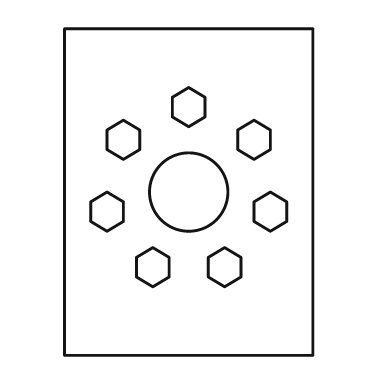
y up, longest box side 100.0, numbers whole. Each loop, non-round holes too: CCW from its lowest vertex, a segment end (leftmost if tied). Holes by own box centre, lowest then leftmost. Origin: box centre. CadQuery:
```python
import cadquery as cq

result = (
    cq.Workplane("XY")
    .moveTo(-38.0, -50.0)
    .lineTo(38.0, -50.0)
    .lineTo(38.0, 50.0)
    .lineTo(-38.0, 50.0)
    .close()
    .moveTo(-11.0, -29.0)
    .lineTo(-6.0, -26.0)
    .lineTo(-6.0, -20.0)
    .lineTo(-11.0, -17.0)
    .lineTo(-16.0, -20.0)
    .lineTo(-16.0, -26.0)
    .close()
    .moveTo(11.0, -29.0)
    .lineTo(16.0, -26.0)
    .lineTo(16.0, -20.0)
    .lineTo(11.0, -17.0)
    .lineTo(6.0, -20.0)
    .lineTo(6.0, -26.0)
    .close()
    .moveTo(-25.0, -12.0)
    .lineTo(-20.0, -9.0)
    .lineTo(-20.0, -3.0)
    .lineTo(-25.0, 0.0)
    .lineTo(-30.0, -3.0)
    .lineTo(-30.0, -9.0)
    .close()
    .moveTo(25.0, -12.0)
    .lineTo(30.0, -9.0)
    .lineTo(30.0, -3.0)
    .lineTo(25.0, 0.0)
    .lineTo(20.0, -3.0)
    .lineTo(20.0, -9.0)
    .close()
    .moveTo(0.0, 0.0)
    .circle(12.0)
    .moveTo(-20.0, 10.0)
    .lineTo(-15.0, 13.0)
    .lineTo(-15.0, 19.0)
    .lineTo(-20.0, 22.0)
    .lineTo(-25.0, 19.0)
    .lineTo(-25.0, 13.0)
    .close()
    .moveTo(20.0, 10.0)
    .lineTo(25.0, 13.0)
    .lineTo(25.0, 19.0)
    .lineTo(20.0, 22.0)
    .lineTo(15.0, 19.0)
    .lineTo(15.0, 13.0)
    .close()
    .moveTo(0.0, 20.0)
    .lineTo(5.0, 23.0)
    .lineTo(5.0, 29.0)
    .lineTo(0.0, 32.0)
    .lineTo(-5.0, 29.0)
    .lineTo(-5.0, 23.0)
    .close()
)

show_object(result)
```